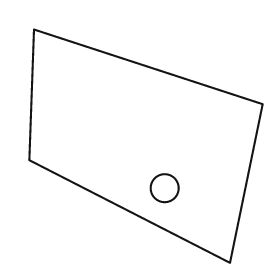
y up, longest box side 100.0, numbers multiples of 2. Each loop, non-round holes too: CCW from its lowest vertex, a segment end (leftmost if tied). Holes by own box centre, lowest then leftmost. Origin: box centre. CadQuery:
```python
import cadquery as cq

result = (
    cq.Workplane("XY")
    .moveTo(36.0, -50.0)
    .lineTo(50.0, 18.0)
    .lineTo(-48.0, 50.0)
    .lineTo(-50.0, -6.0)
    .close()
    .moveTo(8.0, -18.0)
    .circle(6.0)
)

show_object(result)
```